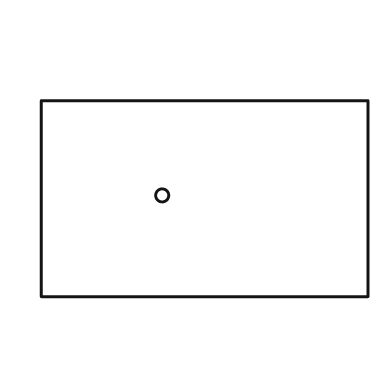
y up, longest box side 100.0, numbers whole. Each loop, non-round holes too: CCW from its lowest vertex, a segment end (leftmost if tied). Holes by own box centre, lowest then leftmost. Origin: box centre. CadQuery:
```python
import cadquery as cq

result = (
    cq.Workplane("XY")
    .moveTo(-50.0, -30.0)
    .lineTo(50.0, -30.0)
    .lineTo(50.0, 30.0)
    .lineTo(-50.0, 30.0)
    .close()
    .moveTo(-13.0, 1.0)
    .circle(2.0)
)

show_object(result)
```